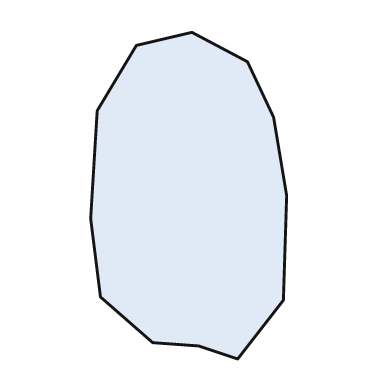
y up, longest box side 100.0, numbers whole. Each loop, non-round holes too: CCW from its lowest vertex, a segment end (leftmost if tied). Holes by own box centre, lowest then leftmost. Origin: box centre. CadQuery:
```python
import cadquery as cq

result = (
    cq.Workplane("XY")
    .moveTo(15.0, -50.0)
    .lineTo(29.0, -32.0)
    .lineTo(30.0, 0.0)
    .lineTo(26.0, 24.0)
    .lineTo(18.0, 41.0)
    .lineTo(1.0, 50.0)
    .lineTo(-16.0, 46.0)
    .lineTo(-28.0, 26.0)
    .lineTo(-30.0, -7.0)
    .lineTo(-27.0, -31.0)
    .lineTo(-11.0, -45.0)
    .lineTo(3.0, -46.0)
    .close()
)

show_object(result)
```